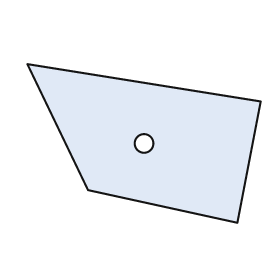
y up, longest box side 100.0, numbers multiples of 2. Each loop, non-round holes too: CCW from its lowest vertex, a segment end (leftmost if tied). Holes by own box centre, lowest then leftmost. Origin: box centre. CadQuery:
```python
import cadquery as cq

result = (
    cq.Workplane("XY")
    .moveTo(40.0, -34.0)
    .lineTo(50.0, 18.0)
    .lineTo(-50.0, 34.0)
    .lineTo(-24.0, -20.0)
    .close()
    .moveTo(0.0, 0.0)
    .circle(4.0)
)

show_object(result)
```